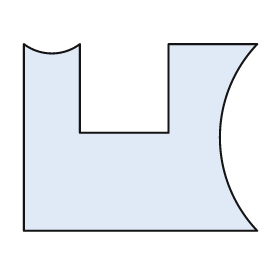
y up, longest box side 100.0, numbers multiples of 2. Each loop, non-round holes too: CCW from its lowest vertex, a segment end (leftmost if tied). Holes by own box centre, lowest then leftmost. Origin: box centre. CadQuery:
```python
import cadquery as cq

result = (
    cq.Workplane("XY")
    .moveTo(-50.0, -40.0)
    .lineTo(50.0, -40.0)
    .threePointArc((34.0, 0.0), (50.0, 40.0))
    .lineTo(12.0, 40.0)
    .lineTo(12.0, 2.0)
    .lineTo(-26.0, 2.0)
    .lineTo(-26.0, 40.0)
    .threePointArc((-38.0, 36.0), (-50.0, 40.0))
    .close()
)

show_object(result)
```